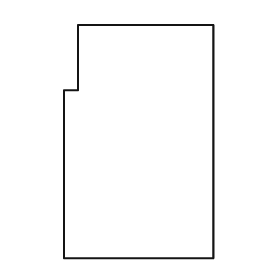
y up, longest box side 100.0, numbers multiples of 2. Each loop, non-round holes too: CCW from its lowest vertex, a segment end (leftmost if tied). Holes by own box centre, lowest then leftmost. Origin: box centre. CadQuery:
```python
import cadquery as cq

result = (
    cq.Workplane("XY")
    .moveTo(-32.0, -50.0)
    .lineTo(32.0, -50.0)
    .lineTo(32.0, 50.0)
    .lineTo(-26.0, 50.0)
    .lineTo(-26.0, 22.0)
    .lineTo(-32.0, 22.0)
    .close()
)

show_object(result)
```